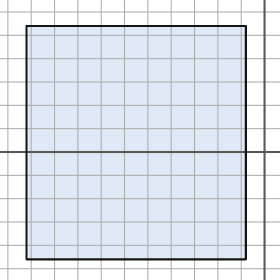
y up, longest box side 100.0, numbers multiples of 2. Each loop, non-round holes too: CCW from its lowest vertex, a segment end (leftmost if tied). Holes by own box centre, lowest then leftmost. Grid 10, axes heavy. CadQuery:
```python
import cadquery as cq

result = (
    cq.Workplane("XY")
    .moveTo(-102.0, -46.0)
    .lineTo(-8.0, -46.0)
    .lineTo(-8.0, 54.0)
    .lineTo(-102.0, 54.0)
    .close()
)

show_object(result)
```